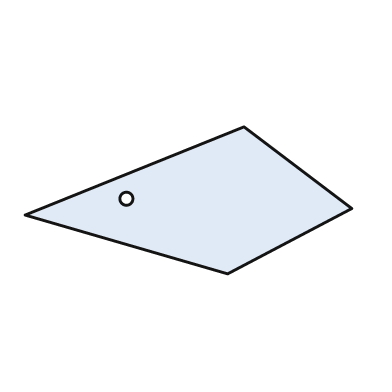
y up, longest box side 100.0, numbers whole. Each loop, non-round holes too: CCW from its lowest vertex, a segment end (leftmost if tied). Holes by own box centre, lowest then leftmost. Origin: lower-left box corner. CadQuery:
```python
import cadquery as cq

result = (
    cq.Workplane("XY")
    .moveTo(62.0, 0.0)
    .lineTo(100.0, 20.0)
    .lineTo(67.0, 45.0)
    .lineTo(0.0, 18.0)
    .close()
    .moveTo(31.0, 23.0)
    .circle(2.0)
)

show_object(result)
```